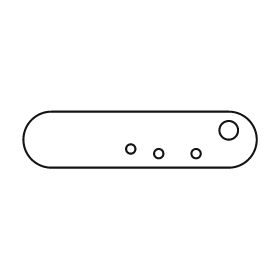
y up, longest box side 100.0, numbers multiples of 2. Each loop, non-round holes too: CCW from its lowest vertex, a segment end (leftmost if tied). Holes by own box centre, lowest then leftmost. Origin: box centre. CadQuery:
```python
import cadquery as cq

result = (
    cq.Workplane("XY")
    .moveTo(-38.0, -12.0)
    .lineTo(38.0, -12.0)
    .threePointArc((50.0, 0.0), (38.0, 12.0))
    .lineTo(-38.0, 12.0)
    .threePointArc((-50.0, 0.0), (-38.0, -12.0))
    .close()
    .moveTo(8.0, -6.0)
    .circle(2.0)
    .moveTo(24.0, -6.0)
    .circle(2.0)
    .moveTo(-4.0, -4.0)
    .circle(2.0)
    .moveTo(38.0, 4.0)
    .circle(4.0)
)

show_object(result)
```